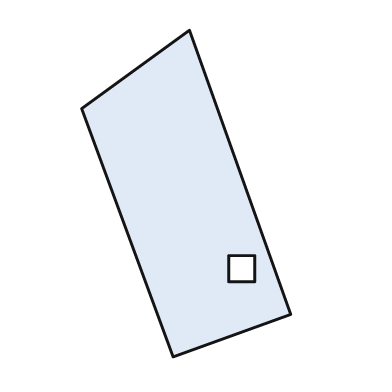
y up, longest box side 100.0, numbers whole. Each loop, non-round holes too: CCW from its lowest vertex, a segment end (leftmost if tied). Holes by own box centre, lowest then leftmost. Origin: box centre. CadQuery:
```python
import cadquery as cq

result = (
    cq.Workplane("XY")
    .moveTo(-4.0, -50.0)
    .lineTo(32.0, -37.0)
    .lineTo(1.0, 50.0)
    .lineTo(-32.0, 26.0)
    .close()
    .moveTo(13.0, -27.0)
    .lineTo(21.0, -27.0)
    .lineTo(21.0, -19.0)
    .lineTo(13.0, -19.0)
    .close()
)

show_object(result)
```